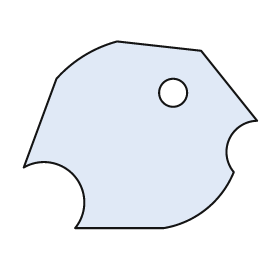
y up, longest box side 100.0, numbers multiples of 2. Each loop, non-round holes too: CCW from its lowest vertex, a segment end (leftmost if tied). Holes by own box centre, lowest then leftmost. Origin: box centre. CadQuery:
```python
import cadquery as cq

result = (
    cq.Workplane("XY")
    .moveTo(-28.0, -40.0)
    .lineTo(10.0, -40.0)
    .threePointArc((28.0, -32.0), (40.0, -16.0))
    .threePointArc((38.0, -2.0), (50.0, 6.0))
    .lineTo(26.0, 36.0)
    .lineTo(-10.0, 40.0)
    .threePointArc((-24.0, 34.0), (-36.0, 24.0))
    .lineTo(-50.0, -14.0)
    .threePointArc((-28.0, -18.0), (-28.0, -40.0))
    .close()
    .moveTo(14.0, 18.0)
    .circle(6.0)
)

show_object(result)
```